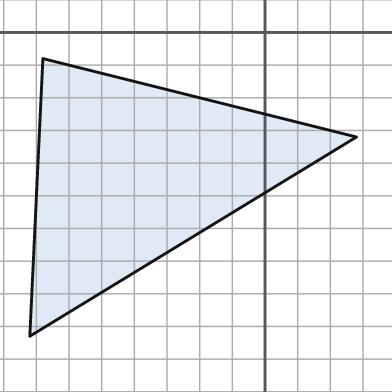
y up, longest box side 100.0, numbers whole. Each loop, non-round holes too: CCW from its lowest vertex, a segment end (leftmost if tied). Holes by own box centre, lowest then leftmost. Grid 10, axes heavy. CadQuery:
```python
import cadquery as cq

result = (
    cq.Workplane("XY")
    .moveTo(-72.0, -93.0)
    .lineTo(28.0, -32.0)
    .lineTo(-68.0, -8.0)
    .close()
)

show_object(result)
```